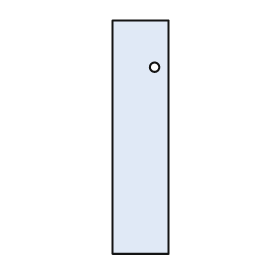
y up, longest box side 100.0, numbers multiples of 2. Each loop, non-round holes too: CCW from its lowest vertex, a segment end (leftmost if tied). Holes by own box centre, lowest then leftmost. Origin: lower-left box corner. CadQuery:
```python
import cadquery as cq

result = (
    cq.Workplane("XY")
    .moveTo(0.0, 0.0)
    .lineTo(24.0, 0.0)
    .lineTo(24.0, 100.0)
    .lineTo(0.0, 100.0)
    .close()
    .moveTo(18.0, 80.0)
    .circle(2.0)
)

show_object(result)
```